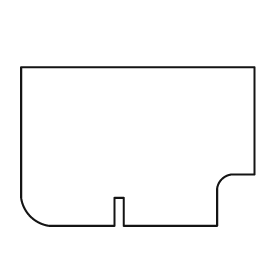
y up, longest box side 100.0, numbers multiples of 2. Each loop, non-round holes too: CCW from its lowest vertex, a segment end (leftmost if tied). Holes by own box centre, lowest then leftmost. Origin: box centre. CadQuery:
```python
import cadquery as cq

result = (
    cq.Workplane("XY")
    .moveTo(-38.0, -34.0)
    .lineTo(-10.0, -34.0)
    .lineTo(-10.0, -22.0)
    .lineTo(-6.0, -22.0)
    .lineTo(-6.0, -34.0)
    .lineTo(34.0, -34.0)
    .lineTo(34.0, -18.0)
    .threePointArc((36.0, -14.0), (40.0, -12.0))
    .lineTo(50.0, -12.0)
    .lineTo(50.0, 34.0)
    .lineTo(-50.0, 34.0)
    .lineTo(-50.0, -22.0)
    .threePointArc((-46.0, -30.0), (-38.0, -34.0))
    .close()
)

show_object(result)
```